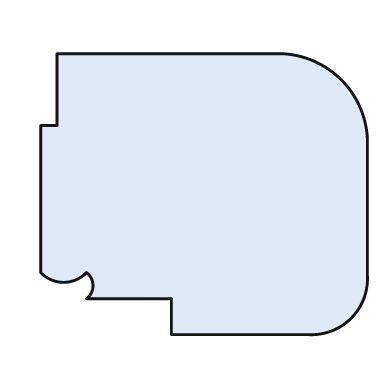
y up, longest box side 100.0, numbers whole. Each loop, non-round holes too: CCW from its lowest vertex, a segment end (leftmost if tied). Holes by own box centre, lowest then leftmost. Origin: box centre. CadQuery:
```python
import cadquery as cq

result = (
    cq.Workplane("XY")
    .moveTo(-10.0, -43.0)
    .lineTo(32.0, -43.0)
    .threePointArc((45.0, -38.0), (50.0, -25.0))
    .lineTo(50.0, 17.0)
    .threePointArc((42.0, 35.0), (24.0, 43.0))
    .lineTo(-45.0, 43.0)
    .lineTo(-45.0, 21.0)
    .lineTo(-50.0, 21.0)
    .lineTo(-50.0, -24.0)
    .threePointArc((-43.0, -27.0), (-36.0, -24.0))
    .threePointArc((-34.0, -28.0), (-36.0, -32.0))
    .lineTo(-10.0, -32.0)
    .close()
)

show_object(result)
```